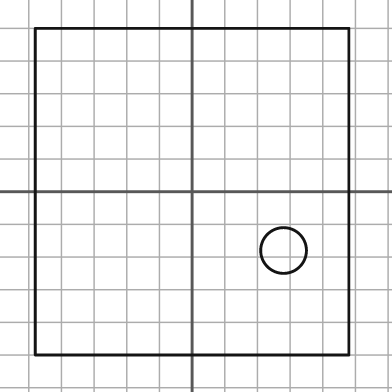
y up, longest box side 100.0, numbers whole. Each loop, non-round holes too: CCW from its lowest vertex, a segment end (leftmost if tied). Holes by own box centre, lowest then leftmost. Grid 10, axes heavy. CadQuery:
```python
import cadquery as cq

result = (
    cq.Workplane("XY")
    .moveTo(-48.0, -50.0)
    .lineTo(48.0, -50.0)
    .lineTo(48.0, 50.0)
    .lineTo(-48.0, 50.0)
    .close()
    .moveTo(28.0, -18.0)
    .circle(7.0)
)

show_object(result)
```